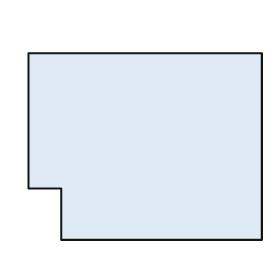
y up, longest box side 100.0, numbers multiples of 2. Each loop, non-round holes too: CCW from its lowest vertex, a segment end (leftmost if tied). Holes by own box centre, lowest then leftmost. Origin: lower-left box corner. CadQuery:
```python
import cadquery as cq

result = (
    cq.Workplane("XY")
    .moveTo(14.0, 0.0)
    .lineTo(100.0, 0.0)
    .lineTo(100.0, 80.0)
    .lineTo(0.0, 80.0)
    .lineTo(0.0, 22.0)
    .lineTo(14.0, 22.0)
    .close()
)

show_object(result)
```